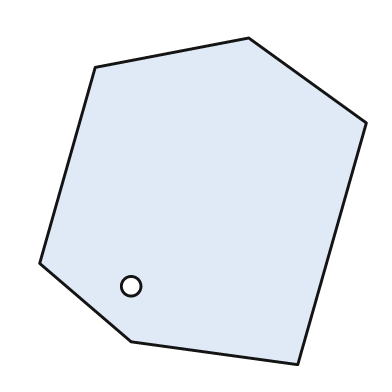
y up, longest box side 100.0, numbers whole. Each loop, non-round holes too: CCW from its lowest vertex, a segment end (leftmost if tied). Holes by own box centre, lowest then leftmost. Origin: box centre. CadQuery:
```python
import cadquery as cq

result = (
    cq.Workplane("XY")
    .moveTo(29.0, -50.0)
    .lineTo(50.0, 24.0)
    .lineTo(14.0, 50.0)
    .lineTo(-33.0, 41.0)
    .lineTo(-50.0, -19.0)
    .lineTo(-22.0, -43.0)
    .close()
    .moveTo(-22.0, -26.0)
    .circle(3.0)
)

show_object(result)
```